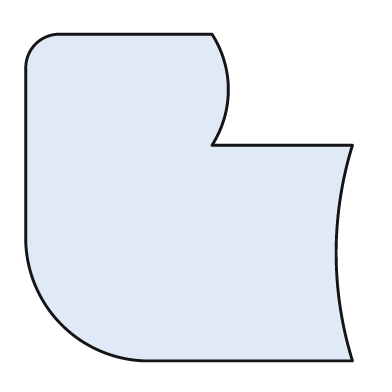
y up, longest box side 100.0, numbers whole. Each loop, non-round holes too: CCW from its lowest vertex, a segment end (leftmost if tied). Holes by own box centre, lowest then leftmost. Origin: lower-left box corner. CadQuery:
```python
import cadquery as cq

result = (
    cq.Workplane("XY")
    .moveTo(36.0, 0.0)
    .lineTo(100.0, 0.0)
    .threePointArc((95.0, 33.0), (100.0, 66.0))
    .lineTo(57.0, 66.0)
    .threePointArc((62.0, 83.0), (57.0, 100.0))
    .lineTo(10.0, 100.0)
    .threePointArc((3.0, 97.0), (0.0, 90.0))
    .lineTo(0.0, 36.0)
    .threePointArc((11.0, 11.0), (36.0, 0.0))
    .close()
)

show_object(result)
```